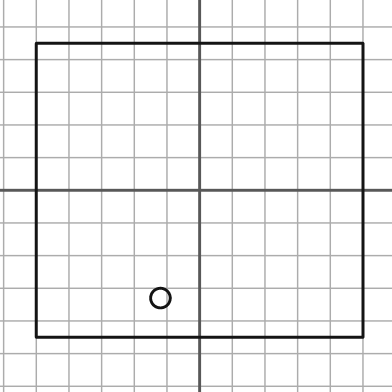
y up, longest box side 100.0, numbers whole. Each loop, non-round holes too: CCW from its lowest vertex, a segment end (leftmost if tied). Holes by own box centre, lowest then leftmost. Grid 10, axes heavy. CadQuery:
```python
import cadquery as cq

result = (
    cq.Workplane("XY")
    .moveTo(-50.0, -45.0)
    .lineTo(50.0, -45.0)
    .lineTo(50.0, 45.0)
    .lineTo(-50.0, 45.0)
    .close()
    .moveTo(-12.0, -33.0)
    .circle(3.0)
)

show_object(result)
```